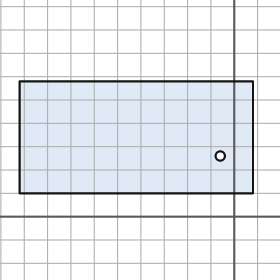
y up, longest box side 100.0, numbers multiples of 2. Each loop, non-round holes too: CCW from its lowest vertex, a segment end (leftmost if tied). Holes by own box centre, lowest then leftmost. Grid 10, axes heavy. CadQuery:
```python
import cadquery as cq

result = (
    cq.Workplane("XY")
    .moveTo(-92.0, 10.0)
    .lineTo(8.0, 10.0)
    .lineTo(8.0, 58.0)
    .lineTo(-92.0, 58.0)
    .close()
    .moveTo(-6.0, 26.0)
    .circle(2.0)
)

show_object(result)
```